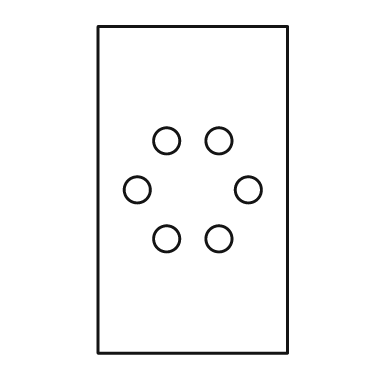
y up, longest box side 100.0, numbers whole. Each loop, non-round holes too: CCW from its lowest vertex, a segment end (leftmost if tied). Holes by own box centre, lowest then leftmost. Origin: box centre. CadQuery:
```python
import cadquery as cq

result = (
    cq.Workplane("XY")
    .moveTo(-29.0, -50.0)
    .lineTo(29.0, -50.0)
    .lineTo(29.0, 50.0)
    .lineTo(-29.0, 50.0)
    .close()
    .moveTo(-8.0, -15.0)
    .circle(4.0)
    .moveTo(8.0, -15.0)
    .circle(4.0)
    .moveTo(-17.0, 0.0)
    .circle(4.0)
    .moveTo(17.0, 0.0)
    .circle(4.0)
    .moveTo(-8.0, 15.0)
    .circle(4.0)
    .moveTo(8.0, 15.0)
    .circle(4.0)
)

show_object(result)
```